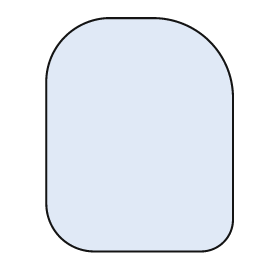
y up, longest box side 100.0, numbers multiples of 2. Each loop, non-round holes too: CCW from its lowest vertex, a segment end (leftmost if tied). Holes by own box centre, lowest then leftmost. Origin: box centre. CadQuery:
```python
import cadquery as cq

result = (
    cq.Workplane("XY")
    .moveTo(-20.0, -50.0)
    .lineTo(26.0, -50.0)
    .threePointArc((36.0, -46.0), (40.0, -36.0))
    .lineTo(40.0, 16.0)
    .threePointArc((30.0, 40.0), (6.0, 50.0))
    .lineTo(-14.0, 50.0)
    .threePointArc((-32.0, 42.0), (-40.0, 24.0))
    .lineTo(-40.0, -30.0)
    .threePointArc((-34.0, -44.0), (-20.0, -50.0))
    .close()
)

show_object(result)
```